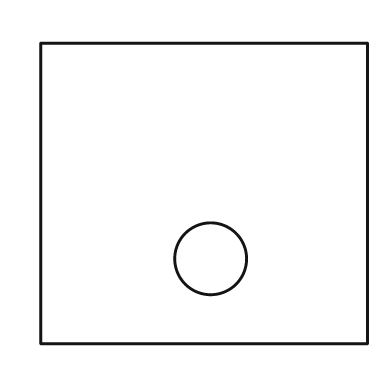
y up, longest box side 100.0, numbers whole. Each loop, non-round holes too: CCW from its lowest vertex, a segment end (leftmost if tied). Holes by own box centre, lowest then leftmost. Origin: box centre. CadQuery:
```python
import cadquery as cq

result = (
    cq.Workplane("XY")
    .moveTo(-50.0, -46.0)
    .lineTo(50.0, -46.0)
    .lineTo(50.0, 46.0)
    .lineTo(-50.0, 46.0)
    .close()
    .moveTo(2.0, -20.0)
    .circle(11.0)
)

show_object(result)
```